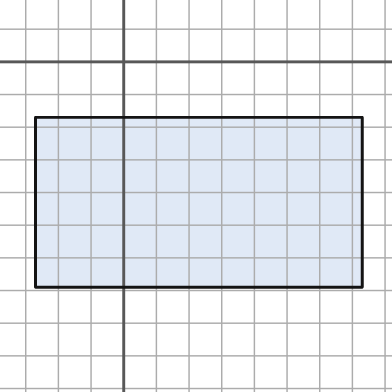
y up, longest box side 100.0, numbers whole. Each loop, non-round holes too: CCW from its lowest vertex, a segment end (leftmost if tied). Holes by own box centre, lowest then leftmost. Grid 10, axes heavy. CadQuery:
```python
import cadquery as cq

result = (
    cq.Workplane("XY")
    .moveTo(-27.0, -69.0)
    .lineTo(73.0, -69.0)
    .lineTo(73.0, -17.0)
    .lineTo(-27.0, -17.0)
    .close()
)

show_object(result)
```